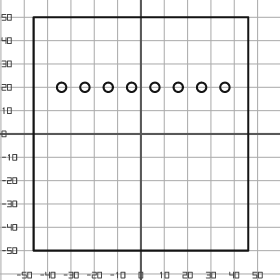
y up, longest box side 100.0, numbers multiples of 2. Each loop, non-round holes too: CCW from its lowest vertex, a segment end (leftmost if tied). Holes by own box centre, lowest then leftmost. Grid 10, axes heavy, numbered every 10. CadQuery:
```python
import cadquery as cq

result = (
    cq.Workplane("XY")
    .moveTo(-46.0, -50.0)
    .lineTo(46.0, -50.0)
    .lineTo(46.0, 50.0)
    .lineTo(-46.0, 50.0)
    .close()
    .moveTo(-34.0, 20.0)
    .circle(2.0)
    .moveTo(-24.0, 20.0)
    .circle(2.0)
    .moveTo(-14.0, 20.0)
    .circle(2.0)
    .moveTo(-4.0, 20.0)
    .circle(2.0)
    .moveTo(6.0, 20.0)
    .circle(2.0)
    .moveTo(16.0, 20.0)
    .circle(2.0)
    .moveTo(26.0, 20.0)
    .circle(2.0)
    .moveTo(36.0, 20.0)
    .circle(2.0)
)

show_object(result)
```